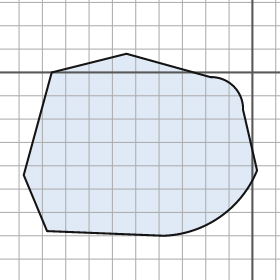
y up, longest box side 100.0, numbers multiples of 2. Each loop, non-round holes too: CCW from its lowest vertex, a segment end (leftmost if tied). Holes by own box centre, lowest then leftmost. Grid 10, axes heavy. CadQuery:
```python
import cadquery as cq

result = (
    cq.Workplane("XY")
    .moveTo(-38.0, -70.0)
    .threePointArc((-14.0, -62.0), (2.0, -42.0))
    .lineTo(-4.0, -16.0)
    .threePointArc((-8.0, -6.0), (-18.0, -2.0))
    .lineTo(-54.0, 8.0)
    .lineTo(-86.0, 0.0)
    .lineTo(-98.0, -44.0)
    .lineTo(-88.0, -68.0)
    .close()
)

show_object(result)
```